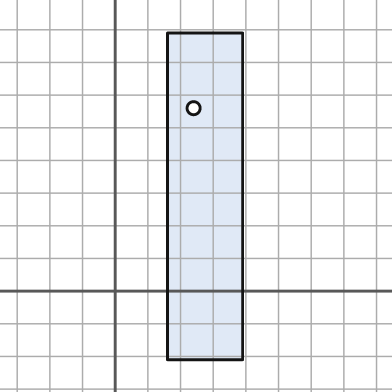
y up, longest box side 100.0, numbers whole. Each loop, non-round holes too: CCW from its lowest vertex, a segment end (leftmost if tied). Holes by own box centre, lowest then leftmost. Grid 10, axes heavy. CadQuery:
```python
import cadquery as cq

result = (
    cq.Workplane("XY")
    .moveTo(16.0, -21.0)
    .lineTo(39.0, -21.0)
    .lineTo(39.0, 79.0)
    .lineTo(16.0, 79.0)
    .close()
    .moveTo(24.0, 56.0)
    .circle(2.0)
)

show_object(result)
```